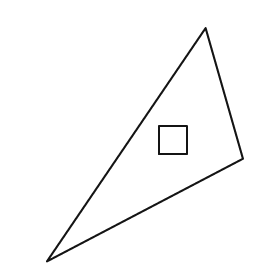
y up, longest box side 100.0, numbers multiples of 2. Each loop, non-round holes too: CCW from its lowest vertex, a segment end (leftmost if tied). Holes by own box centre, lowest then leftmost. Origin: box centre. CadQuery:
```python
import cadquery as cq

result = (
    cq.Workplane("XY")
    .moveTo(-42.0, -50.0)
    .lineTo(42.0, -6.0)
    .lineTo(26.0, 50.0)
    .close()
    .moveTo(6.0, -4.0)
    .lineTo(18.0, -4.0)
    .lineTo(18.0, 8.0)
    .lineTo(6.0, 8.0)
    .close()
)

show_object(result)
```